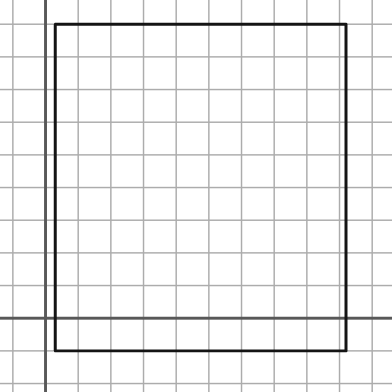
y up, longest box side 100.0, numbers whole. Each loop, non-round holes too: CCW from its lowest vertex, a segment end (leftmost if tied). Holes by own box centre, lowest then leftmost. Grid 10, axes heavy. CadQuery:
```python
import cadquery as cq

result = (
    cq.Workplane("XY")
    .moveTo(3.0, -10.0)
    .lineTo(92.0, -10.0)
    .lineTo(92.0, 90.0)
    .lineTo(3.0, 90.0)
    .close()
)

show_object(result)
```